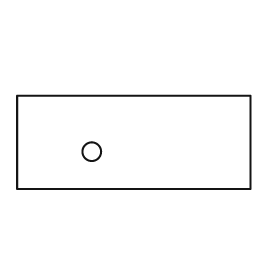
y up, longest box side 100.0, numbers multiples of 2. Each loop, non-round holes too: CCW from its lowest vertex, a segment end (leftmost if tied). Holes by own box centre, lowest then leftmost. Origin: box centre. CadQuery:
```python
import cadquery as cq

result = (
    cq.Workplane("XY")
    .moveTo(-50.0, -20.0)
    .lineTo(50.0, -20.0)
    .lineTo(50.0, 20.0)
    .lineTo(-50.0, 20.0)
    .close()
    .moveTo(-18.0, -4.0)
    .circle(4.0)
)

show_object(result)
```